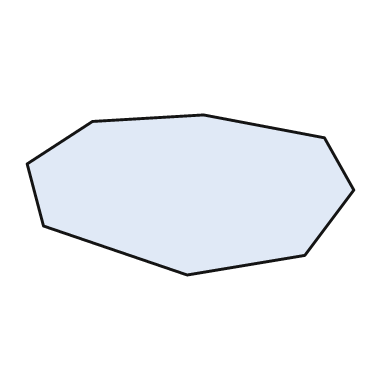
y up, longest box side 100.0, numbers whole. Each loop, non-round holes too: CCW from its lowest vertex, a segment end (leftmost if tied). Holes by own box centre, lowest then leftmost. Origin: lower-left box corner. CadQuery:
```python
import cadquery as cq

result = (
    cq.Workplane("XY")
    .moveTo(49.0, 0.0)
    .lineTo(85.0, 6.0)
    .lineTo(100.0, 26.0)
    .lineTo(91.0, 42.0)
    .lineTo(54.0, 49.0)
    .lineTo(20.0, 47.0)
    .lineTo(0.0, 34.0)
    .lineTo(5.0, 15.0)
    .close()
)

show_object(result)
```